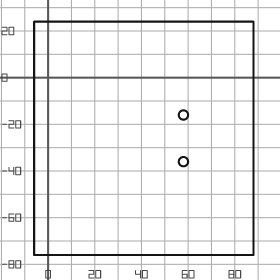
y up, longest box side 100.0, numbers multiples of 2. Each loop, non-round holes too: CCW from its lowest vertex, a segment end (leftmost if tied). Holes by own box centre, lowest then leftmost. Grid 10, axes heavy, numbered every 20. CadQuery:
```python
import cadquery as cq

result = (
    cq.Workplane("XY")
    .moveTo(-6.0, -76.0)
    .lineTo(88.0, -76.0)
    .lineTo(88.0, 24.0)
    .lineTo(-6.0, 24.0)
    .close()
    .moveTo(58.0, -36.0)
    .circle(2.0)
    .moveTo(58.0, -16.0)
    .circle(2.0)
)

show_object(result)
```